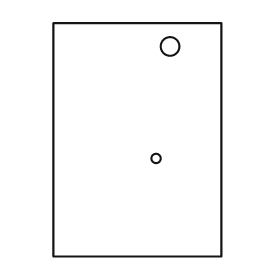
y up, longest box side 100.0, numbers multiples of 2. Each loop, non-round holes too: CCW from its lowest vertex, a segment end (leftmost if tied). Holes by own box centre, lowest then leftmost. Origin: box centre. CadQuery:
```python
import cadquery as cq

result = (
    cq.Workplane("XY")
    .moveTo(-36.0, -50.0)
    .lineTo(36.0, -50.0)
    .lineTo(36.0, 50.0)
    .lineTo(-36.0, 50.0)
    .close()
    .moveTo(8.0, -8.0)
    .circle(2.0)
    .moveTo(14.0, 40.0)
    .circle(4.0)
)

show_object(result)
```